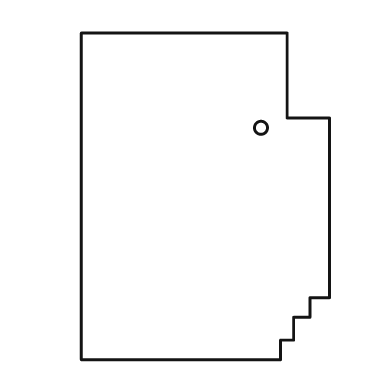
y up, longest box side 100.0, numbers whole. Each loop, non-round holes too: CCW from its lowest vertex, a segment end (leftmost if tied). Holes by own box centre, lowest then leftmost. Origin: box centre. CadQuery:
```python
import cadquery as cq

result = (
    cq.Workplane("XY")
    .moveTo(-38.0, -50.0)
    .lineTo(23.0, -50.0)
    .lineTo(23.0, -44.0)
    .lineTo(27.0, -44.0)
    .lineTo(27.0, -37.0)
    .lineTo(32.0, -37.0)
    .lineTo(32.0, -31.0)
    .lineTo(38.0, -31.0)
    .lineTo(38.0, 24.0)
    .lineTo(25.0, 24.0)
    .lineTo(25.0, 50.0)
    .lineTo(-38.0, 50.0)
    .close()
    .moveTo(17.0, 21.0)
    .circle(2.0)
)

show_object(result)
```